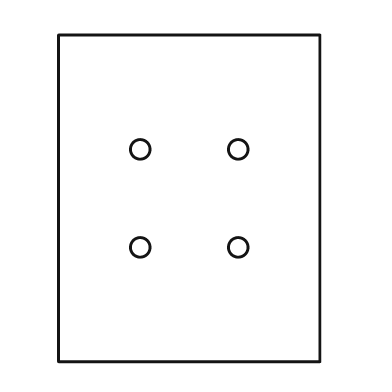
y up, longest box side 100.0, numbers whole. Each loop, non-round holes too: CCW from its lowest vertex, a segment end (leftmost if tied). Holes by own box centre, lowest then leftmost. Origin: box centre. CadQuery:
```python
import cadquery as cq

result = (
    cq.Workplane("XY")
    .moveTo(-40.0, -50.0)
    .lineTo(40.0, -50.0)
    .lineTo(40.0, 50.0)
    .lineTo(-40.0, 50.0)
    .close()
    .moveTo(-15.0, -15.0)
    .circle(3.0)
    .moveTo(15.0, -15.0)
    .circle(3.0)
    .moveTo(-15.0, 15.0)
    .circle(3.0)
    .moveTo(15.0, 15.0)
    .circle(3.0)
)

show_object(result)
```